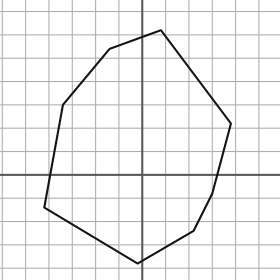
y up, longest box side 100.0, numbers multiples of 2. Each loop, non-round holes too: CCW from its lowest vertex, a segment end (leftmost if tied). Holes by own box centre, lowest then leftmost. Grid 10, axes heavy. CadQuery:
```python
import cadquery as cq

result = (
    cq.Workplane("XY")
    .moveTo(-2.0, -38.0)
    .lineTo(22.0, -24.0)
    .lineTo(30.0, -8.0)
    .lineTo(38.0, 22.0)
    .lineTo(8.0, 62.0)
    .lineTo(-14.0, 54.0)
    .lineTo(-34.0, 30.0)
    .lineTo(-42.0, -14.0)
    .close()
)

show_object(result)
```